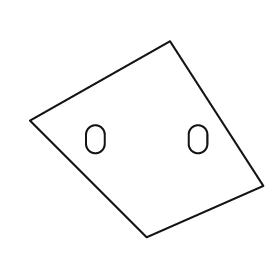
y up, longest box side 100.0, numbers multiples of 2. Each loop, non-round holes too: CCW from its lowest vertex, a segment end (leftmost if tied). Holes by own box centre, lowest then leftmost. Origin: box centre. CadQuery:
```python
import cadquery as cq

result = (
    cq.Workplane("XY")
    .moveTo(0.0, -42.0)
    .lineTo(50.0, -20.0)
    .lineTo(10.0, 42.0)
    .lineTo(-50.0, 8.0)
    .close()
    .moveTo(-26.0, -2.0)
    .threePointArc((-22.0, -6.0), (-18.0, -2.0))
    .lineTo(-18.0, 2.0)
    .threePointArc((-22.0, 6.0), (-26.0, 2.0))
    .close()
    .moveTo(18.0, -2.0)
    .threePointArc((22.0, -6.0), (26.0, -2.0))
    .lineTo(26.0, 2.0)
    .threePointArc((22.0, 6.0), (18.0, 2.0))
    .close()
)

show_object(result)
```